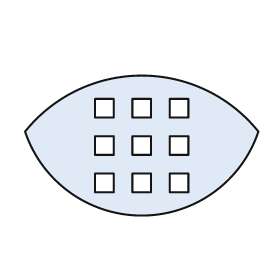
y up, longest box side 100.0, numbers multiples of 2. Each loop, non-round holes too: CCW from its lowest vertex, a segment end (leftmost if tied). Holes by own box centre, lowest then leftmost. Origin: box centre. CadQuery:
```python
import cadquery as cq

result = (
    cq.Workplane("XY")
    .moveTo(-50.0, 6.0)
    .threePointArc((0.0, -30.0), (50.0, 6.0))
    .threePointArc((0.0, 30.0), (-50.0, 6.0))
    .close()
    .moveTo(-20.0, -20.0)
    .lineTo(-12.0, -20.0)
    .lineTo(-12.0, -12.0)
    .lineTo(-20.0, -12.0)
    .close()
    .moveTo(-4.0, -20.0)
    .lineTo(4.0, -20.0)
    .lineTo(4.0, -12.0)
    .lineTo(-4.0, -12.0)
    .close()
    .moveTo(12.0, -20.0)
    .lineTo(20.0, -20.0)
    .lineTo(20.0, -12.0)
    .lineTo(12.0, -12.0)
    .close()
    .moveTo(-20.0, -4.0)
    .lineTo(-12.0, -4.0)
    .lineTo(-12.0, 4.0)
    .lineTo(-20.0, 4.0)
    .close()
    .moveTo(-4.0, -4.0)
    .lineTo(4.0, -4.0)
    .lineTo(4.0, 4.0)
    .lineTo(-4.0, 4.0)
    .close()
    .moveTo(12.0, -4.0)
    .lineTo(20.0, -4.0)
    .lineTo(20.0, 4.0)
    .lineTo(12.0, 4.0)
    .close()
    .moveTo(-20.0, 12.0)
    .lineTo(-12.0, 12.0)
    .lineTo(-12.0, 20.0)
    .lineTo(-20.0, 20.0)
    .close()
    .moveTo(-4.0, 12.0)
    .lineTo(4.0, 12.0)
    .lineTo(4.0, 20.0)
    .lineTo(-4.0, 20.0)
    .close()
    .moveTo(12.0, 12.0)
    .lineTo(20.0, 12.0)
    .lineTo(20.0, 20.0)
    .lineTo(12.0, 20.0)
    .close()
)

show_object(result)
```